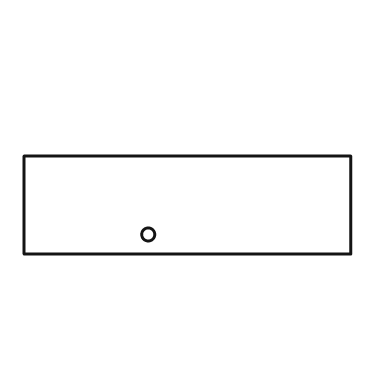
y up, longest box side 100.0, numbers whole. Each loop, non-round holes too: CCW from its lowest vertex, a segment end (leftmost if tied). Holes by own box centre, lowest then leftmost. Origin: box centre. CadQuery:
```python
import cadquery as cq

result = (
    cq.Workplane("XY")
    .moveTo(-50.0, -15.0)
    .lineTo(50.0, -15.0)
    .lineTo(50.0, 15.0)
    .lineTo(-50.0, 15.0)
    .close()
    .moveTo(-12.0, -9.0)
    .circle(2.0)
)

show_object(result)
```